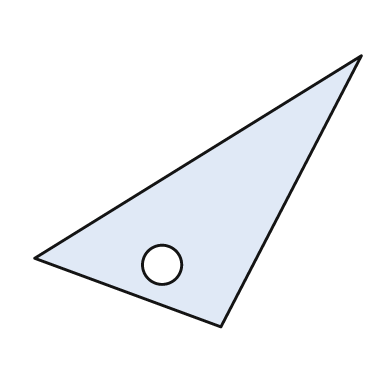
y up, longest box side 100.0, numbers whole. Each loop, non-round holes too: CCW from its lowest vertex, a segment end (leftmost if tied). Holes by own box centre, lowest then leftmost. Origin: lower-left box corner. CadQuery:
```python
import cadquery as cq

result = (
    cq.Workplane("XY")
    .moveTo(57.0, 0.0)
    .lineTo(100.0, 83.0)
    .lineTo(0.0, 21.0)
    .close()
    .moveTo(39.0, 19.0)
    .circle(6.0)
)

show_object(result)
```